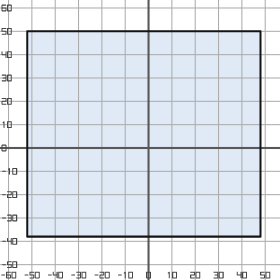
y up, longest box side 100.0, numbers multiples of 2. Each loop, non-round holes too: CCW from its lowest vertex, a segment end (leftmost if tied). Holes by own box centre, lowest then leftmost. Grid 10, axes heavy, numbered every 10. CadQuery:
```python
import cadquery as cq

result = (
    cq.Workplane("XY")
    .moveTo(-52.0, -38.0)
    .lineTo(48.0, -38.0)
    .lineTo(48.0, 50.0)
    .lineTo(-52.0, 50.0)
    .close()
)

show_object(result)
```